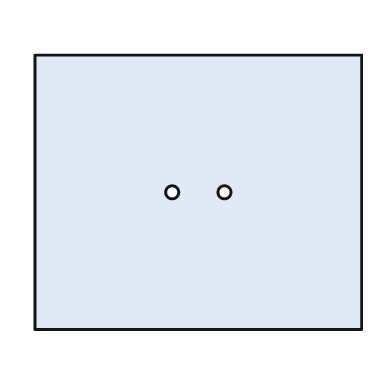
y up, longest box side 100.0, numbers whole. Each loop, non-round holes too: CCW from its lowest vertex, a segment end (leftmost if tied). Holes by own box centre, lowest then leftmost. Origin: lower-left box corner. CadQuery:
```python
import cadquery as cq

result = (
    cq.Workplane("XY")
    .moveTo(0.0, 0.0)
    .lineTo(100.0, 0.0)
    .lineTo(100.0, 84.0)
    .lineTo(0.0, 84.0)
    .close()
    .moveTo(42.0, 42.0)
    .circle(2.0)
    .moveTo(58.0, 42.0)
    .circle(2.0)
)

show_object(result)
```